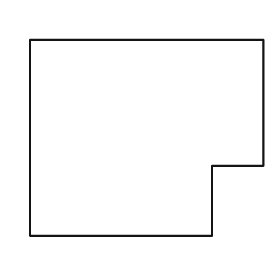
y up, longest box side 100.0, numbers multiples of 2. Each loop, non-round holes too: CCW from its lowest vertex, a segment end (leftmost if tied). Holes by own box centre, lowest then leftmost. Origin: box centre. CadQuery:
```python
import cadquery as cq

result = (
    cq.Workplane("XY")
    .moveTo(-50.0, -42.0)
    .lineTo(28.0, -42.0)
    .lineTo(28.0, -12.0)
    .lineTo(50.0, -12.0)
    .lineTo(50.0, 42.0)
    .lineTo(-50.0, 42.0)
    .close()
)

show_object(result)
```